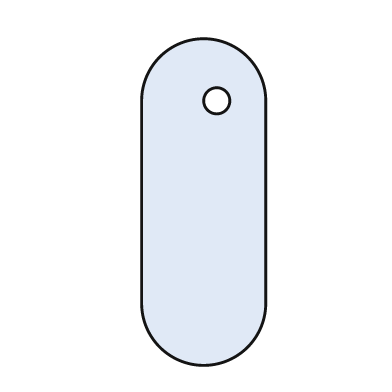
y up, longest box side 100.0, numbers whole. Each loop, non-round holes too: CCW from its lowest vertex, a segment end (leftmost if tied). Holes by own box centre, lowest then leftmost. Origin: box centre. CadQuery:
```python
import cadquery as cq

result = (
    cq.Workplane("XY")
    .moveTo(-19.0, -31.0)
    .threePointArc((0.0, -50.0), (19.0, -31.0))
    .lineTo(19.0, 31.0)
    .threePointArc((0.0, 50.0), (-19.0, 31.0))
    .close()
    .moveTo(4.0, 31.0)
    .circle(4.0)
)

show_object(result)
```